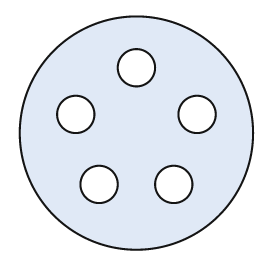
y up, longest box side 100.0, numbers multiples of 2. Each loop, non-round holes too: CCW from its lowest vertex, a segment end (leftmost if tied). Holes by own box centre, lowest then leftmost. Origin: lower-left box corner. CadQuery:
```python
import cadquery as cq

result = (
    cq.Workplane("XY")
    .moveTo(50.0, 50.0)
    .circle(50.0)
    .moveTo(34.0, 28.0)
    .circle(8.0)
    .moveTo(66.0, 28.0)
    .circle(8.0)
    .moveTo(24.0, 58.0)
    .circle(8.0)
    .moveTo(76.0, 58.0)
    .circle(8.0)
    .moveTo(50.0, 78.0)
    .circle(8.0)
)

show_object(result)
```